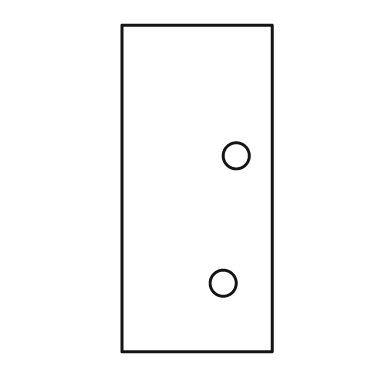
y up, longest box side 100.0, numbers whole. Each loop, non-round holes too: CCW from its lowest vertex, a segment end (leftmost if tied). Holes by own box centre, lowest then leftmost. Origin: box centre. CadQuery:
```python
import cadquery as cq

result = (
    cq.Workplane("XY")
    .moveTo(-23.0, -50.0)
    .lineTo(23.0, -50.0)
    .lineTo(23.0, 50.0)
    .lineTo(-23.0, 50.0)
    .close()
    .moveTo(8.0, -29.0)
    .circle(4.0)
    .moveTo(12.0, 10.0)
    .circle(4.0)
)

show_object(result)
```